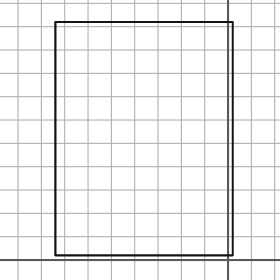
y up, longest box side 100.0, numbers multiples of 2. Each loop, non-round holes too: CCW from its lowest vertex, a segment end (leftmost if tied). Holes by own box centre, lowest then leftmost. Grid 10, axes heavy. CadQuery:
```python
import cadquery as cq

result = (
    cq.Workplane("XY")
    .moveTo(-74.0, 2.0)
    .lineTo(2.0, 2.0)
    .lineTo(2.0, 102.0)
    .lineTo(-74.0, 102.0)
    .close()
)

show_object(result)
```